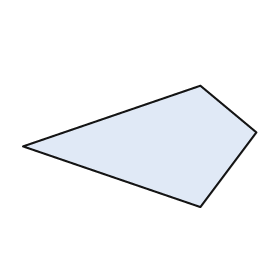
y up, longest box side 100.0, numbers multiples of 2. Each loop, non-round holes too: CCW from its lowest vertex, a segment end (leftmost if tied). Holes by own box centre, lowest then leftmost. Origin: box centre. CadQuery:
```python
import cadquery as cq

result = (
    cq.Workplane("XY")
    .moveTo(26.0, -26.0)
    .lineTo(50.0, 6.0)
    .lineTo(26.0, 26.0)
    .lineTo(-50.0, 0.0)
    .close()
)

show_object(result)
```